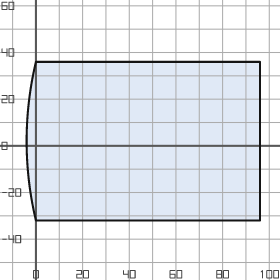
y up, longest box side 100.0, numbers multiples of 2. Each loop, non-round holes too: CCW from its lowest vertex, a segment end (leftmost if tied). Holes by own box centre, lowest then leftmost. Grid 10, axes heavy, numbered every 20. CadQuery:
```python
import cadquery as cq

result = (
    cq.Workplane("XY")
    .moveTo(0.0, -32.0)
    .lineTo(96.0, -32.0)
    .lineTo(96.0, 36.0)
    .lineTo(0.0, 36.0)
    .threePointArc((-4.0, 2.0), (0.0, -32.0))
    .close()
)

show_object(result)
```